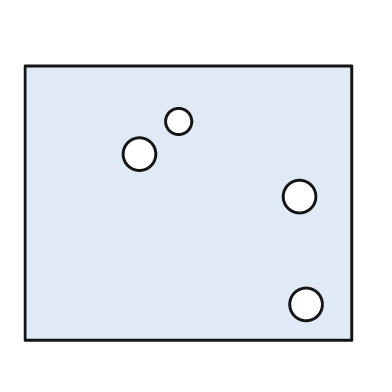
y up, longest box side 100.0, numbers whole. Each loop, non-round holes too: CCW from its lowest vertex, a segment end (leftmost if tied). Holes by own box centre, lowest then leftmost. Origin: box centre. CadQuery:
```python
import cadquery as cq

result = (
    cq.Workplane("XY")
    .moveTo(-50.0, -42.0)
    .lineTo(50.0, -42.0)
    .lineTo(50.0, 42.0)
    .lineTo(-50.0, 42.0)
    .close()
    .moveTo(36.0, -31.0)
    .circle(5.0)
    .moveTo(34.0, 2.0)
    .circle(5.0)
    .moveTo(-15.0, 15.0)
    .circle(5.0)
    .moveTo(-3.0, 25.0)
    .circle(4.0)
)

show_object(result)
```